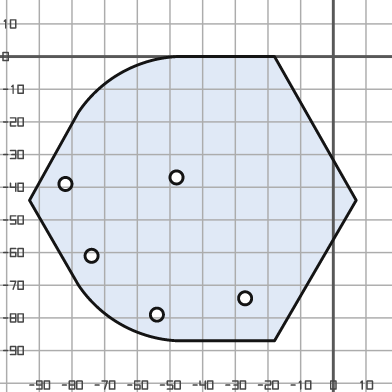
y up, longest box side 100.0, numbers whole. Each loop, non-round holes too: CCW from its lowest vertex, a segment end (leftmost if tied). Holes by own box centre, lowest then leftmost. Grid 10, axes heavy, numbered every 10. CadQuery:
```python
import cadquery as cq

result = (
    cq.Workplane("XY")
    .moveTo(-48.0, -87.0)
    .lineTo(-18.0, -87.0)
    .lineTo(7.0, -44.0)
    .lineTo(-18.0, 0.0)
    .lineTo(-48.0, 0.0)
    .threePointArc((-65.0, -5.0), (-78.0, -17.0))
    .lineTo(-93.0, -44.0)
    .lineTo(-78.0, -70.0)
    .threePointArc((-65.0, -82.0), (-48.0, -87.0))
    .close()
    .moveTo(-54.0, -79.0)
    .circle(2.0)
    .moveTo(-27.0, -74.0)
    .circle(2.0)
    .moveTo(-74.0, -61.0)
    .circle(2.0)
    .moveTo(-82.0, -39.0)
    .circle(2.0)
    .moveTo(-48.0, -37.0)
    .circle(2.0)
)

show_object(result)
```